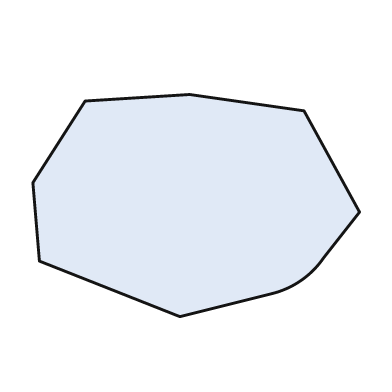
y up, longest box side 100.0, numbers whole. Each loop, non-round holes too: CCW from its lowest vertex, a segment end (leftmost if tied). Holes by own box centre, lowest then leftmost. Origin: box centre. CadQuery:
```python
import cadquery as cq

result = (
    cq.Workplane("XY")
    .moveTo(-5.0, -34.0)
    .lineTo(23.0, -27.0)
    .threePointArc((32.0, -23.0), (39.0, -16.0))
    .lineTo(50.0, -2.0)
    .lineTo(33.0, 29.0)
    .lineTo(-2.0, 34.0)
    .lineTo(-34.0, 32.0)
    .lineTo(-50.0, 7.0)
    .lineTo(-48.0, -17.0)
    .close()
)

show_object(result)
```